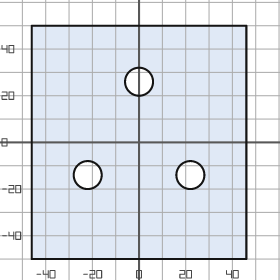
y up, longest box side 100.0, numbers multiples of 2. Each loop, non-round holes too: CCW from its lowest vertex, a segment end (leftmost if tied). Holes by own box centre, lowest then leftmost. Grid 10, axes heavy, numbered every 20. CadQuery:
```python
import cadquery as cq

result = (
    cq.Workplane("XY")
    .moveTo(-46.0, -50.0)
    .lineTo(46.0, -50.0)
    .lineTo(46.0, 50.0)
    .lineTo(-46.0, 50.0)
    .close()
    .moveTo(-22.0, -14.0)
    .circle(6.0)
    .moveTo(22.0, -14.0)
    .circle(6.0)
    .moveTo(0.0, 26.0)
    .circle(6.0)
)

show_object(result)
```